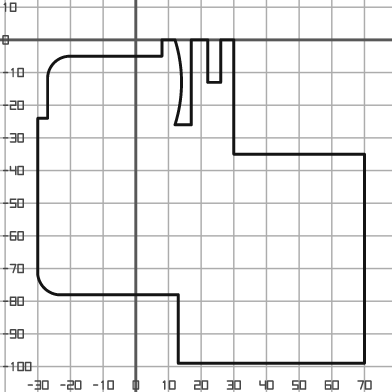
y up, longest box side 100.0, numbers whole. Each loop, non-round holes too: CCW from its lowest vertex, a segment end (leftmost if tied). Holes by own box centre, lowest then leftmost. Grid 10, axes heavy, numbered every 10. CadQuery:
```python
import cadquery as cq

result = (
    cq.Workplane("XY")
    .moveTo(13.0, -99.0)
    .lineTo(70.0, -99.0)
    .lineTo(70.0, -35.0)
    .lineTo(30.0, -35.0)
    .lineTo(30.0, 0.0)
    .lineTo(26.0, 0.0)
    .lineTo(26.0, -13.0)
    .lineTo(22.0, -13.0)
    .lineTo(22.0, 0.0)
    .lineTo(17.0, 0.0)
    .lineTo(17.0, -26.0)
    .lineTo(12.0, -26.0)
    .threePointArc((14.0, -13.0), (12.0, 0.0))
    .lineTo(8.0, 0.0)
    .lineTo(8.0, -5.0)
    .lineTo(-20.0, -5.0)
    .threePointArc((-25.0, -7.0), (-27.0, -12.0))
    .lineTo(-27.0, -24.0)
    .lineTo(-30.0, -24.0)
    .lineTo(-30.0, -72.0)
    .threePointArc((-28.0, -76.0), (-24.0, -78.0))
    .lineTo(13.0, -78.0)
    .close()
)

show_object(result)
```